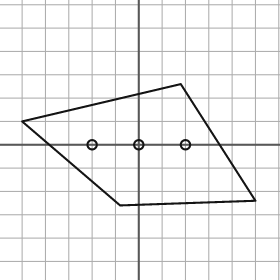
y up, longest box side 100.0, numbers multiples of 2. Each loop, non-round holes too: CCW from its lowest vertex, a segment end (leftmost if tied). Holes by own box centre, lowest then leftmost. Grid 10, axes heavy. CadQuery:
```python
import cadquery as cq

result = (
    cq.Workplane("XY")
    .moveTo(-8.0, -26.0)
    .lineTo(50.0, -24.0)
    .lineTo(18.0, 26.0)
    .lineTo(-50.0, 10.0)
    .close()
    .moveTo(-20.0, 0.0)
    .circle(2.0)
    .moveTo(0.0, 0.0)
    .circle(2.0)
    .moveTo(20.0, 0.0)
    .circle(2.0)
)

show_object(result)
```